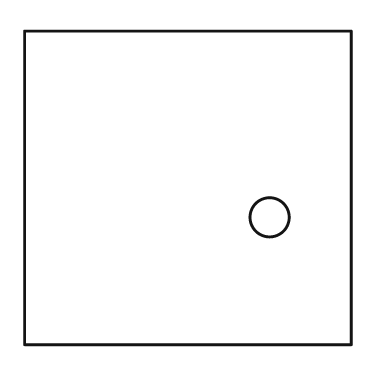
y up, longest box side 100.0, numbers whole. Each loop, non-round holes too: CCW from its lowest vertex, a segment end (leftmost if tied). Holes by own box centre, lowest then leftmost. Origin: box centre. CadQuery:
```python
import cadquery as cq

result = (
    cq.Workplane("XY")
    .moveTo(-50.0, -48.0)
    .lineTo(50.0, -48.0)
    .lineTo(50.0, 48.0)
    .lineTo(-50.0, 48.0)
    .close()
    .moveTo(25.0, -9.0)
    .circle(6.0)
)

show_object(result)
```